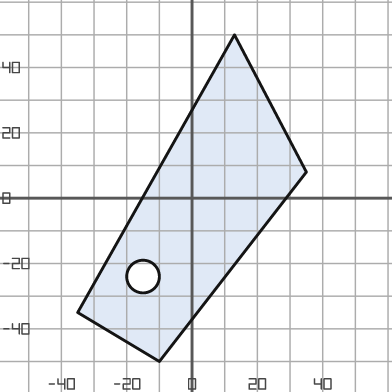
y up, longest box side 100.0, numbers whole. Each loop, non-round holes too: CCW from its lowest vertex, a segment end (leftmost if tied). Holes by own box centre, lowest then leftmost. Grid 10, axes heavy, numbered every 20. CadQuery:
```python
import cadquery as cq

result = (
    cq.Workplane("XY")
    .moveTo(-10.0, -50.0)
    .lineTo(35.0, 8.0)
    .lineTo(13.0, 50.0)
    .lineTo(-35.0, -35.0)
    .close()
    .moveTo(-15.0, -24.0)
    .circle(5.0)
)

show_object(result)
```